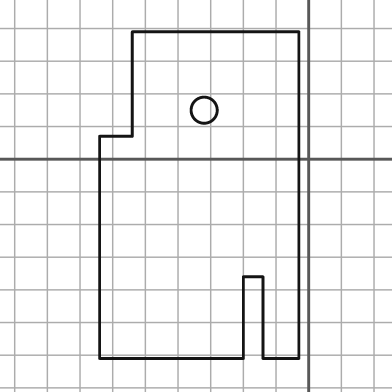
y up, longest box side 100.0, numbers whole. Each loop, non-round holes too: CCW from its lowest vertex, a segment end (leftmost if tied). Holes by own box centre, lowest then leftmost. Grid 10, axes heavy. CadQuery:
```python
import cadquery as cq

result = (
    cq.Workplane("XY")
    .moveTo(-64.0, -61.0)
    .lineTo(-20.0, -61.0)
    .lineTo(-20.0, -36.0)
    .lineTo(-14.0, -36.0)
    .lineTo(-14.0, -61.0)
    .lineTo(-3.0, -61.0)
    .lineTo(-3.0, 39.0)
    .lineTo(-54.0, 39.0)
    .lineTo(-54.0, 7.0)
    .lineTo(-64.0, 7.0)
    .close()
    .moveTo(-32.0, 15.0)
    .circle(4.0)
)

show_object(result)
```